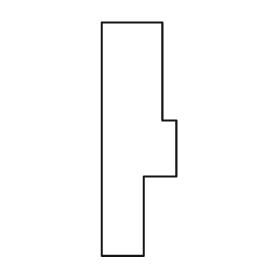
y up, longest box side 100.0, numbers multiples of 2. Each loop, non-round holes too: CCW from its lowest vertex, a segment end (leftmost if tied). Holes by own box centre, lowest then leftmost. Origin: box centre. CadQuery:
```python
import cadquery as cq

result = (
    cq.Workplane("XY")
    .moveTo(-16.0, -50.0)
    .lineTo(2.0, -50.0)
    .lineTo(2.0, -16.0)
    .lineTo(16.0, -16.0)
    .lineTo(16.0, 8.0)
    .lineTo(10.0, 8.0)
    .lineTo(10.0, 50.0)
    .lineTo(-16.0, 50.0)
    .close()
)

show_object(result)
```